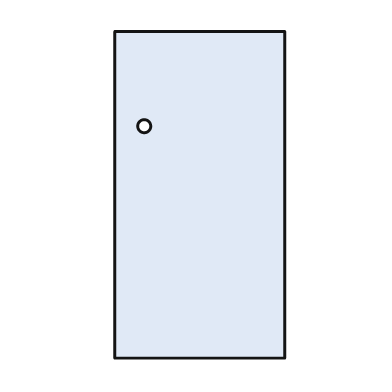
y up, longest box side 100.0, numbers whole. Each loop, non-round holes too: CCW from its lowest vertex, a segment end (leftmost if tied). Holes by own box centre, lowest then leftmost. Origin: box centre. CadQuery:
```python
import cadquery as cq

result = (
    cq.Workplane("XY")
    .moveTo(-26.0, -50.0)
    .lineTo(26.0, -50.0)
    .lineTo(26.0, 50.0)
    .lineTo(-26.0, 50.0)
    .close()
    .moveTo(-17.0, 21.0)
    .circle(2.0)
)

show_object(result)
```